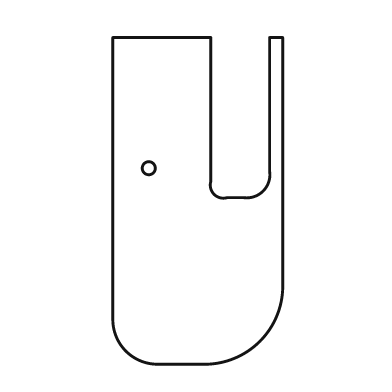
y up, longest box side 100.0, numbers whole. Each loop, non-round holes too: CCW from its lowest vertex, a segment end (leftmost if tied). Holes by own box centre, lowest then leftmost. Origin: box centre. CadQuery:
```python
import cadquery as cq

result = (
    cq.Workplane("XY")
    .moveTo(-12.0, -50.0)
    .lineTo(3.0, -50.0)
    .threePointArc((19.0, -43.0), (26.0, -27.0))
    .lineTo(26.0, 50.0)
    .lineTo(22.0, 50.0)
    .lineTo(22.0, 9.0)
    .threePointArc((20.0, 3.0), (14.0, 1.0))
    .lineTo(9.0, 1.0)
    .threePointArc((5.0, 2.0), (4.0, 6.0))
    .lineTo(4.0, 50.0)
    .lineTo(-26.0, 50.0)
    .lineTo(-26.0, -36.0)
    .threePointArc((-22.0, -46.0), (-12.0, -50.0))
    .close()
    .moveTo(-15.0, 10.0)
    .circle(2.0)
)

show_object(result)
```